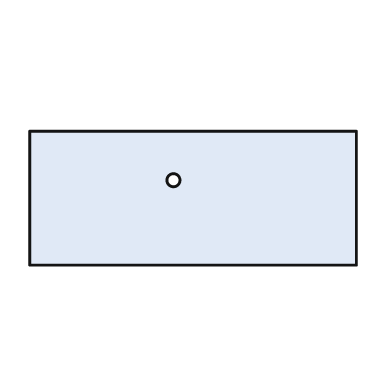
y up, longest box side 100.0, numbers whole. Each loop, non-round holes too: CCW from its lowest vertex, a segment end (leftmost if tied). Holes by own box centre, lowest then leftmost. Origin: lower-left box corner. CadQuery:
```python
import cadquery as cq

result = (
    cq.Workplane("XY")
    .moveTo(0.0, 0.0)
    .lineTo(100.0, 0.0)
    .lineTo(100.0, 41.0)
    .lineTo(0.0, 41.0)
    .close()
    .moveTo(44.0, 26.0)
    .circle(2.0)
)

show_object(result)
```